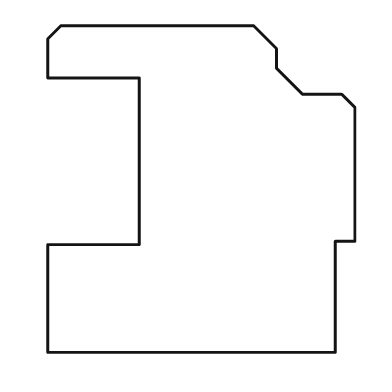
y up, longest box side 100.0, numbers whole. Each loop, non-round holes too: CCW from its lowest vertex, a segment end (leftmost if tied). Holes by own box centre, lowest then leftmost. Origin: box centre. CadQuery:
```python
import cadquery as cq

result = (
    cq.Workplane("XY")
    .moveTo(-47.0, -50.0)
    .lineTo(41.0, -50.0)
    .lineTo(41.0, -16.0)
    .lineTo(47.0, -16.0)
    .lineTo(47.0, 25.0)
    .lineTo(43.0, 29.0)
    .lineTo(31.0, 29.0)
    .lineTo(23.0, 37.0)
    .lineTo(23.0, 43.0)
    .lineTo(16.0, 50.0)
    .lineTo(-43.0, 50.0)
    .lineTo(-47.0, 46.0)
    .lineTo(-47.0, 34.0)
    .lineTo(-19.0, 34.0)
    .lineTo(-19.0, -17.0)
    .lineTo(-47.0, -17.0)
    .close()
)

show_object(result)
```